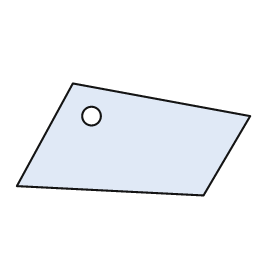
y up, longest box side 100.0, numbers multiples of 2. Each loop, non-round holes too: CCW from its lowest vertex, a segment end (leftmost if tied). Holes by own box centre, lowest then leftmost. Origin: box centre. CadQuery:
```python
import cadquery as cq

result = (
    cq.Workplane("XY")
    .moveTo(30.0, -24.0)
    .lineTo(50.0, 10.0)
    .lineTo(-26.0, 24.0)
    .lineTo(-50.0, -20.0)
    .close()
    .moveTo(-18.0, 10.0)
    .circle(4.0)
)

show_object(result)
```